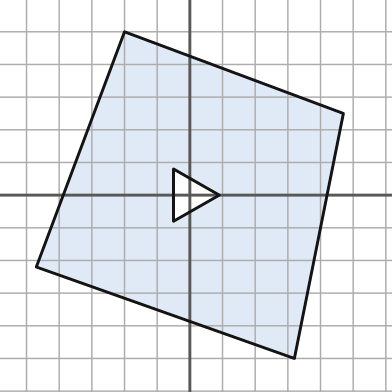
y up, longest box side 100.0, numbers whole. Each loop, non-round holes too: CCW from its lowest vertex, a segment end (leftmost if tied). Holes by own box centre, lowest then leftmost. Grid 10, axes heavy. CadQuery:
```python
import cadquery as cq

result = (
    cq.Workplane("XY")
    .moveTo(32.0, -50.0)
    .lineTo(47.0, 25.0)
    .lineTo(-20.0, 50.0)
    .lineTo(-47.0, -22.0)
    .close()
    .moveTo(-5.0, -8.0)
    .lineTo(9.0, 0.0)
    .lineTo(-5.0, 8.0)
    .close()
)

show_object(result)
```